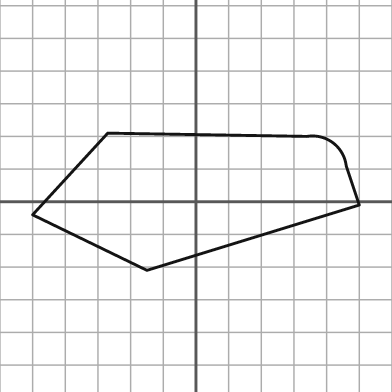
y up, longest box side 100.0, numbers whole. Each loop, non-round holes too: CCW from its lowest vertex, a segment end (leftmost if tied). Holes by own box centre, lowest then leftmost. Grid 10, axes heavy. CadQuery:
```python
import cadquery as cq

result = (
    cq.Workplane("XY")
    .moveTo(-15.0, -21.0)
    .lineTo(50.0, -1.0)
    .lineTo(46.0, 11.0)
    .threePointArc((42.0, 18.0), (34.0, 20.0))
    .lineTo(-27.0, 21.0)
    .lineTo(-50.0, -4.0)
    .close()
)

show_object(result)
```